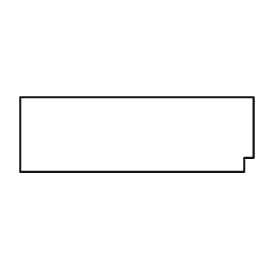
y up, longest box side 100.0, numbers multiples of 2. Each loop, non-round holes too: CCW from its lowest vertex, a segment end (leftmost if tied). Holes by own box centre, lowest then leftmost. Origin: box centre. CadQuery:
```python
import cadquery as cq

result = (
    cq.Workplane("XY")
    .moveTo(-50.0, -16.0)
    .lineTo(46.0, -16.0)
    .lineTo(46.0, -10.0)
    .lineTo(50.0, -10.0)
    .lineTo(50.0, 16.0)
    .lineTo(-50.0, 16.0)
    .close()
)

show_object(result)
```